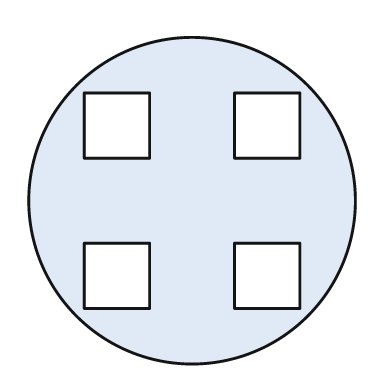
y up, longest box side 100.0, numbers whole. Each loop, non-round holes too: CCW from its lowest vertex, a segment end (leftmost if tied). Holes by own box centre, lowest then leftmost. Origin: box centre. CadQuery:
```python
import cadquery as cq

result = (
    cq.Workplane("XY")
    .moveTo(0.0, 0.0)
    .circle(50.0)
    .moveTo(-33.0, -33.0)
    .lineTo(-13.0, -33.0)
    .lineTo(-13.0, -13.0)
    .lineTo(-33.0, -13.0)
    .close()
    .moveTo(13.0, -33.0)
    .lineTo(33.0, -33.0)
    .lineTo(33.0, -13.0)
    .lineTo(13.0, -13.0)
    .close()
    .moveTo(-33.0, 13.0)
    .lineTo(-13.0, 13.0)
    .lineTo(-13.0, 33.0)
    .lineTo(-33.0, 33.0)
    .close()
    .moveTo(13.0, 13.0)
    .lineTo(33.0, 13.0)
    .lineTo(33.0, 33.0)
    .lineTo(13.0, 33.0)
    .close()
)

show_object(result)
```